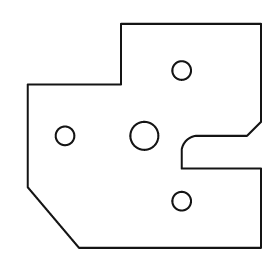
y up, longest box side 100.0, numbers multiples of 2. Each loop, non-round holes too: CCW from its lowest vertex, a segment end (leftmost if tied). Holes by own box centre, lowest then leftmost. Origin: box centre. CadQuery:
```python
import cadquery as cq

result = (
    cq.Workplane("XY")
    .moveTo(-28.0, -48.0)
    .lineTo(50.0, -48.0)
    .lineTo(50.0, -14.0)
    .lineTo(16.0, -14.0)
    .lineTo(16.0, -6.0)
    .threePointArc((18.0, -2.0), (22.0, 0.0))
    .lineTo(44.0, 0.0)
    .lineTo(50.0, 6.0)
    .lineTo(50.0, 48.0)
    .lineTo(-10.0, 48.0)
    .lineTo(-10.0, 22.0)
    .lineTo(-50.0, 22.0)
    .lineTo(-50.0, -22.0)
    .close()
    .moveTo(16.0, -28.0)
    .circle(4.0)
    .moveTo(-34.0, 0.0)
    .circle(4.0)
    .moveTo(0.0, 0.0)
    .circle(6.0)
    .moveTo(16.0, 28.0)
    .circle(4.0)
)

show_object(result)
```